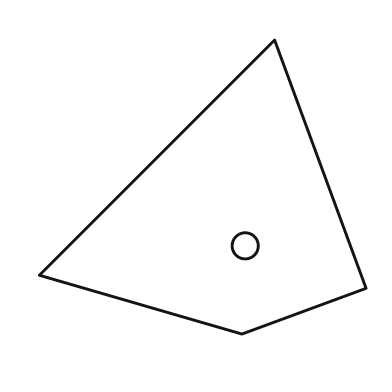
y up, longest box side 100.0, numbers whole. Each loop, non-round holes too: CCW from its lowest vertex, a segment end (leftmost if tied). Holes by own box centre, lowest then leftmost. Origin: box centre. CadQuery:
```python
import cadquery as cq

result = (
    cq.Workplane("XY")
    .moveTo(12.0, -45.0)
    .lineTo(50.0, -31.0)
    .lineTo(22.0, 45.0)
    .lineTo(-50.0, -27.0)
    .close()
    .moveTo(13.0, -18.0)
    .circle(4.0)
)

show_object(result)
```